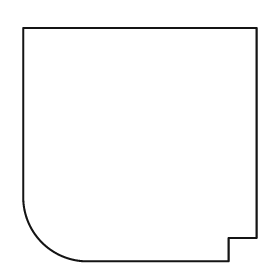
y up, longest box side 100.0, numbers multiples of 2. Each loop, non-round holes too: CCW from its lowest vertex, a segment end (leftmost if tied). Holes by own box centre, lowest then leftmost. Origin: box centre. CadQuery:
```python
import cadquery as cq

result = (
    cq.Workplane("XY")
    .moveTo(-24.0, -50.0)
    .lineTo(38.0, -50.0)
    .lineTo(38.0, -40.0)
    .lineTo(50.0, -40.0)
    .lineTo(50.0, 50.0)
    .lineTo(-50.0, 50.0)
    .lineTo(-50.0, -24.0)
    .threePointArc((-42.0, -42.0), (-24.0, -50.0))
    .close()
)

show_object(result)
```